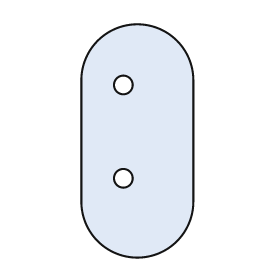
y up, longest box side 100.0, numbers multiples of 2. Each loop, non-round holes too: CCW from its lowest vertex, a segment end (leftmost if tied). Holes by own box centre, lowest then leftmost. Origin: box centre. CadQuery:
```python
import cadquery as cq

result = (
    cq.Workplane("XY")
    .moveTo(-24.0, -26.0)
    .threePointArc((0.0, -50.0), (24.0, -26.0))
    .lineTo(24.0, 26.0)
    .threePointArc((0.0, 50.0), (-24.0, 26.0))
    .close()
    .moveTo(-6.0, -16.0)
    .circle(4.0)
    .moveTo(-6.0, 24.0)
    .circle(4.0)
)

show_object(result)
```